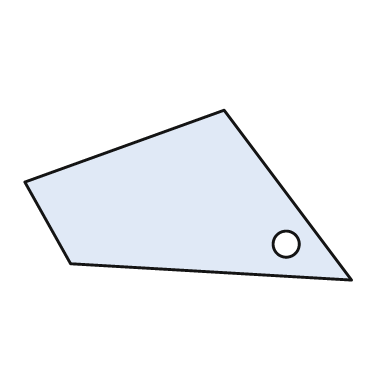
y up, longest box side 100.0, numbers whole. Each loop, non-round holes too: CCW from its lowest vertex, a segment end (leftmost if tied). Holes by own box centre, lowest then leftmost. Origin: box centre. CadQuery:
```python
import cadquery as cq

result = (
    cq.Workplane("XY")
    .moveTo(50.0, -26.0)
    .lineTo(11.0, 26.0)
    .lineTo(-50.0, 4.0)
    .lineTo(-36.0, -21.0)
    .close()
    .moveTo(30.0, -15.0)
    .circle(4.0)
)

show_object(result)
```